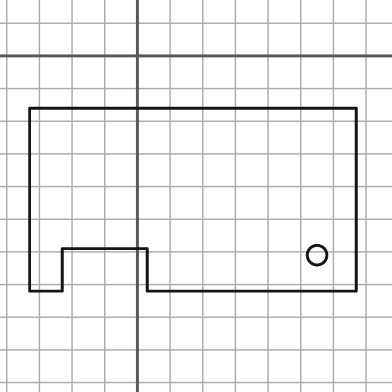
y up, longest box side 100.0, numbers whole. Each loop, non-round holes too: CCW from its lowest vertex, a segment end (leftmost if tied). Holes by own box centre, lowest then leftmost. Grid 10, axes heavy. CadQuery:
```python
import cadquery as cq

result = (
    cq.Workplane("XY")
    .moveTo(-33.0, -72.0)
    .lineTo(-23.0, -72.0)
    .lineTo(-23.0, -59.0)
    .lineTo(3.0, -59.0)
    .lineTo(3.0, -72.0)
    .lineTo(67.0, -72.0)
    .lineTo(67.0, -16.0)
    .lineTo(-33.0, -16.0)
    .close()
    .moveTo(55.0, -61.0)
    .circle(3.0)
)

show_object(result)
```